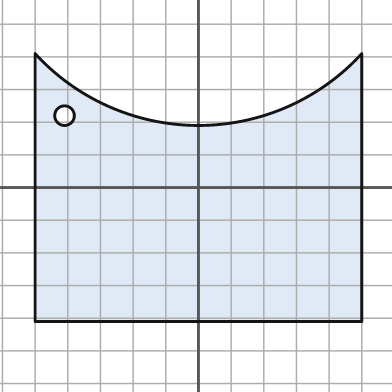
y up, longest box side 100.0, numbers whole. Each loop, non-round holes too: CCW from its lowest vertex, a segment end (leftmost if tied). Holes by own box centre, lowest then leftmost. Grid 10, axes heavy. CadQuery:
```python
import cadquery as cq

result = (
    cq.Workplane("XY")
    .moveTo(-50.0, -41.0)
    .lineTo(50.0, -41.0)
    .lineTo(50.0, 41.0)
    .threePointArc((0.0, 19.0), (-50.0, 41.0))
    .close()
    .moveTo(-41.0, 22.0)
    .circle(3.0)
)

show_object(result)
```